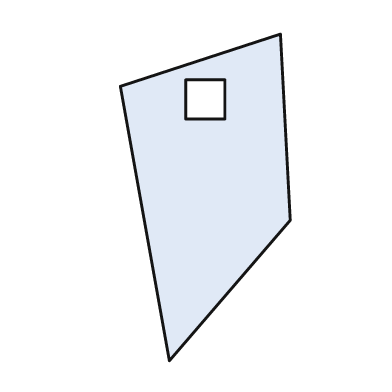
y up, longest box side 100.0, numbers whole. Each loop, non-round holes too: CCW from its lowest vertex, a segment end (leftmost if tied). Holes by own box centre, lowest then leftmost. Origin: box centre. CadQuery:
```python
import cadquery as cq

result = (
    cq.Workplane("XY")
    .moveTo(-11.0, -50.0)
    .lineTo(26.0, -7.0)
    .lineTo(23.0, 50.0)
    .lineTo(-26.0, 34.0)
    .close()
    .moveTo(-6.0, 24.0)
    .lineTo(6.0, 24.0)
    .lineTo(6.0, 36.0)
    .lineTo(-6.0, 36.0)
    .close()
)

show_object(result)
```